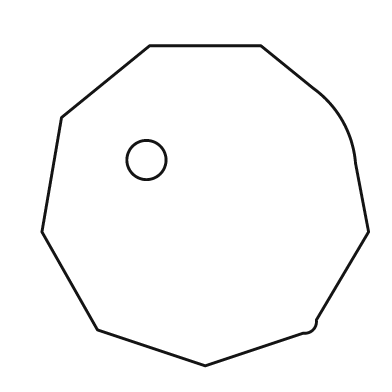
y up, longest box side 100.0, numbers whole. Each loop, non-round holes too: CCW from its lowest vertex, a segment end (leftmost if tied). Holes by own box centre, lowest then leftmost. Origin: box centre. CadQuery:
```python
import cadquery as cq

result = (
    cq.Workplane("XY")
    .moveTo(0.0, -49.0)
    .lineTo(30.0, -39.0)
    .threePointArc((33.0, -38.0), (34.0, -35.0))
    .lineTo(50.0, -8.0)
    .lineTo(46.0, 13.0)
    .threePointArc((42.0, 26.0), (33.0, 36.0))
    .lineTo(17.0, 49.0)
    .lineTo(-17.0, 49.0)
    .lineTo(-44.0, 27.0)
    .lineTo(-50.0, -8.0)
    .lineTo(-33.0, -38.0)
    .close()
    .moveTo(-18.0, 14.0)
    .circle(6.0)
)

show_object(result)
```